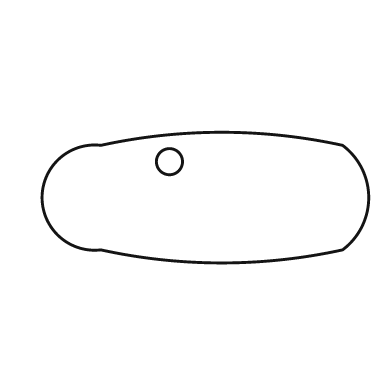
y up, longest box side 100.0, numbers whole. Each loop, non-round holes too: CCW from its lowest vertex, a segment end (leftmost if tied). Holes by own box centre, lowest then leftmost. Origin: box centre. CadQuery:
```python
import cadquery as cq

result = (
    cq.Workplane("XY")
    .moveTo(-32.0, -16.0)
    .threePointArc((5.0, -20.0), (42.0, -16.0))
    .threePointArc((50.0, 0.0), (42.0, 16.0))
    .threePointArc((5.0, 20.0), (-32.0, 16.0))
    .threePointArc((-50.0, 0.0), (-32.0, -16.0))
    .close()
    .moveTo(-11.0, 11.0)
    .circle(4.0)
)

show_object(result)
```